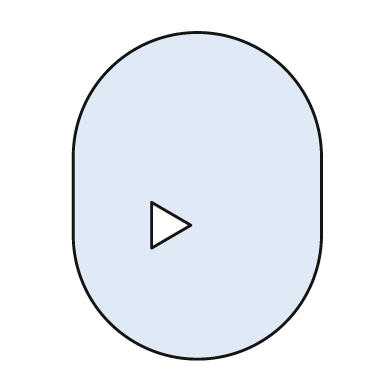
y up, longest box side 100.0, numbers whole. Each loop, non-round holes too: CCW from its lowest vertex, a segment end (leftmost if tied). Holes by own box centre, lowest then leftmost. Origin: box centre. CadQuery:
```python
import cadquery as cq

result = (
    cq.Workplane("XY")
    .moveTo(-38.0, -12.0)
    .threePointArc((0.0, -50.0), (38.0, -12.0))
    .lineTo(38.0, 12.0)
    .threePointArc((0.0, 50.0), (-38.0, 12.0))
    .close()
    .moveTo(-14.0, -16.0)
    .lineTo(-2.0, -9.0)
    .lineTo(-14.0, -2.0)
    .close()
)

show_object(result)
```